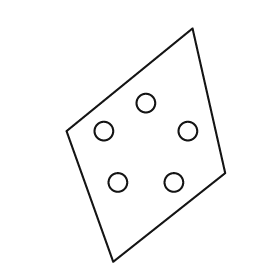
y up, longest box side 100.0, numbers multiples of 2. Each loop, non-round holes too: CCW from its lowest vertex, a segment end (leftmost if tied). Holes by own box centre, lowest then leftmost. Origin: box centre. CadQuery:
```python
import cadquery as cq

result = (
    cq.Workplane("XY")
    .moveTo(-14.0, -50.0)
    .lineTo(34.0, -12.0)
    .lineTo(20.0, 50.0)
    .lineTo(-34.0, 6.0)
    .close()
    .moveTo(-12.0, -16.0)
    .circle(4.0)
    .moveTo(12.0, -16.0)
    .circle(4.0)
    .moveTo(-18.0, 6.0)
    .circle(4.0)
    .moveTo(18.0, 6.0)
    .circle(4.0)
    .moveTo(0.0, 18.0)
    .circle(4.0)
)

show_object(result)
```